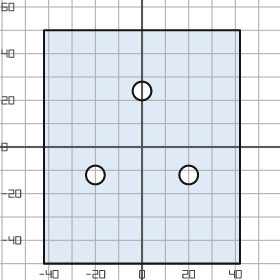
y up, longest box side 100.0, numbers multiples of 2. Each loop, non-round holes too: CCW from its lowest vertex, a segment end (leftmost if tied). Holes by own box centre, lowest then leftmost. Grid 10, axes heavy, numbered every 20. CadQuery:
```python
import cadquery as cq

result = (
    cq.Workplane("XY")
    .moveTo(-42.0, -50.0)
    .lineTo(42.0, -50.0)
    .lineTo(42.0, 50.0)
    .lineTo(-42.0, 50.0)
    .close()
    .moveTo(-20.0, -12.0)
    .circle(4.0)
    .moveTo(20.0, -12.0)
    .circle(4.0)
    .moveTo(0.0, 24.0)
    .circle(4.0)
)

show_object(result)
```